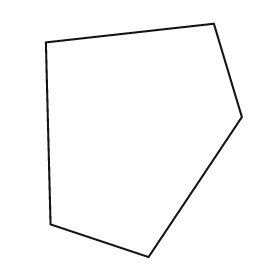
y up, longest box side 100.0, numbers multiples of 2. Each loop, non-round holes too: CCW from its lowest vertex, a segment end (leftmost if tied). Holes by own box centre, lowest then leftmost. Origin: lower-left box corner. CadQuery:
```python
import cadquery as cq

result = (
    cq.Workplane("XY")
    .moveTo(44.0, 0.0)
    .lineTo(84.0, 60.0)
    .lineTo(72.0, 100.0)
    .lineTo(0.0, 92.0)
    .lineTo(2.0, 14.0)
    .close()
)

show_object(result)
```